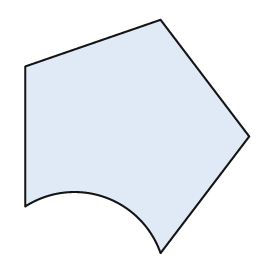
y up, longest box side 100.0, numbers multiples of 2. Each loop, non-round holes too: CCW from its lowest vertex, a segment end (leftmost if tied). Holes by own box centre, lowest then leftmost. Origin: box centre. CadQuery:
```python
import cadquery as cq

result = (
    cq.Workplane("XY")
    .moveTo(10.0, -50.0)
    .lineTo(48.0, 0.0)
    .lineTo(10.0, 50.0)
    .lineTo(-48.0, 30.0)
    .lineTo(-48.0, -30.0)
    .threePointArc((-14.0, -26.0), (10.0, -50.0))
    .close()
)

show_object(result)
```